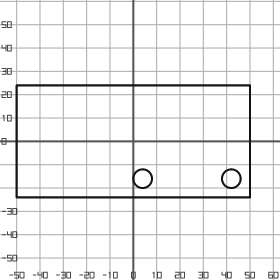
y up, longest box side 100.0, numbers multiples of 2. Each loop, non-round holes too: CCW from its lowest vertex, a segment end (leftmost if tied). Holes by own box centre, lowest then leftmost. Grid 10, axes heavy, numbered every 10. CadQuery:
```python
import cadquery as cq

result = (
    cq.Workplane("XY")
    .moveTo(-50.0, -24.0)
    .lineTo(50.0, -24.0)
    .lineTo(50.0, 24.0)
    .lineTo(-50.0, 24.0)
    .close()
    .moveTo(4.0, -16.0)
    .circle(4.0)
    .moveTo(42.0, -16.0)
    .circle(4.0)
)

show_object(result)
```